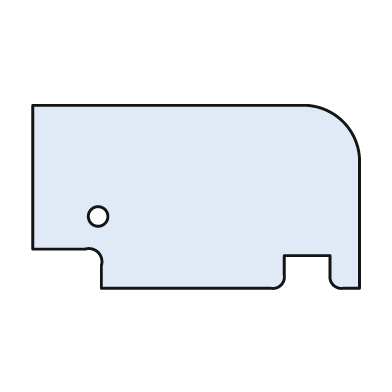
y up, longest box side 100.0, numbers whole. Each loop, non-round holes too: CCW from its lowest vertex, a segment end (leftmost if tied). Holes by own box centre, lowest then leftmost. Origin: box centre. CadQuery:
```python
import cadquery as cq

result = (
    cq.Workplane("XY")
    .moveTo(-29.0, -28.0)
    .lineTo(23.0, -28.0)
    .threePointArc((26.0, -27.0), (27.0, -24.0))
    .lineTo(27.0, -18.0)
    .lineTo(41.0, -18.0)
    .lineTo(41.0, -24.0)
    .threePointArc((42.0, -27.0), (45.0, -28.0))
    .lineTo(50.0, -28.0)
    .lineTo(50.0, 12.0)
    .threePointArc((45.0, 23.0), (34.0, 28.0))
    .lineTo(-50.0, 28.0)
    .lineTo(-50.0, -16.0)
    .lineTo(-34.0, -16.0)
    .threePointArc((-30.0, -17.0), (-29.0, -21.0))
    .close()
    .moveTo(-30.0, -6.0)
    .circle(3.0)
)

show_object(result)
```